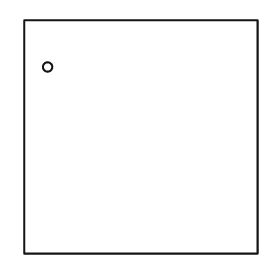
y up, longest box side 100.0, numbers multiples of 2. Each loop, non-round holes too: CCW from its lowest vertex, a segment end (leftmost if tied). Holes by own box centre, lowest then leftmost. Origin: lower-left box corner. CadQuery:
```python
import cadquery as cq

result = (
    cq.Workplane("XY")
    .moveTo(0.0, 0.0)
    .lineTo(100.0, 0.0)
    .lineTo(100.0, 100.0)
    .lineTo(0.0, 100.0)
    .close()
    .moveTo(10.0, 80.0)
    .circle(2.0)
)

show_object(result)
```